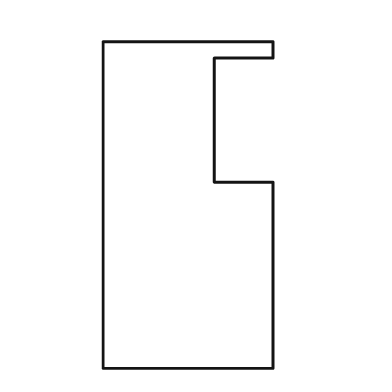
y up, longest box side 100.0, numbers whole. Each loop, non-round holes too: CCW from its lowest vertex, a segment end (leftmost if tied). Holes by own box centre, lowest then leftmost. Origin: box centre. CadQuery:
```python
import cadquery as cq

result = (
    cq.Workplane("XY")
    .moveTo(-26.0, -50.0)
    .lineTo(26.0, -50.0)
    .lineTo(26.0, 7.0)
    .lineTo(8.0, 7.0)
    .lineTo(8.0, 45.0)
    .lineTo(26.0, 45.0)
    .lineTo(26.0, 50.0)
    .lineTo(-26.0, 50.0)
    .close()
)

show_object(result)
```